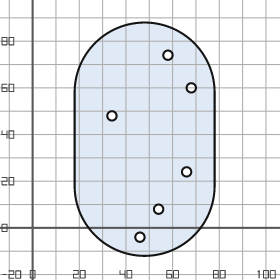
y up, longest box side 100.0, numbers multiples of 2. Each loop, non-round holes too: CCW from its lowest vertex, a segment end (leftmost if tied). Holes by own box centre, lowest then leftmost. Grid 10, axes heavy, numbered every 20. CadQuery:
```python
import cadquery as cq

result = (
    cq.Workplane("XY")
    .moveTo(18.0, 18.0)
    .threePointArc((48.0, -12.0), (78.0, 18.0))
    .lineTo(78.0, 58.0)
    .threePointArc((48.0, 88.0), (18.0, 58.0))
    .close()
    .moveTo(46.0, -4.0)
    .circle(2.0)
    .moveTo(54.0, 8.0)
    .circle(2.0)
    .moveTo(66.0, 24.0)
    .circle(2.0)
    .moveTo(34.0, 48.0)
    .circle(2.0)
    .moveTo(68.0, 60.0)
    .circle(2.0)
    .moveTo(58.0, 74.0)
    .circle(2.0)
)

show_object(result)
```